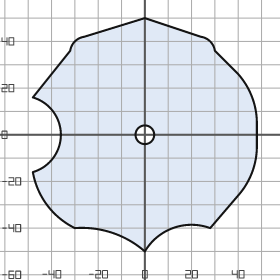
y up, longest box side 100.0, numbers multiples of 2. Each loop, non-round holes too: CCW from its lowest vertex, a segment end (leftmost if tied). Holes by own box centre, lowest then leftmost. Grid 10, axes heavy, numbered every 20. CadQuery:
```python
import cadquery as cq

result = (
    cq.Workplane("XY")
    .moveTo(0.0, -50.0)
    .threePointArc((12.0, -40.0), (28.0, -40.0))
    .lineTo(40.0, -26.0)
    .threePointArc((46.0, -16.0), (48.0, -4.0))
    .lineTo(48.0, 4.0)
    .threePointArc((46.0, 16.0), (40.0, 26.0))
    .lineTo(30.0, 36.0)
    .threePointArc((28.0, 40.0), (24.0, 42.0))
    .lineTo(0.0, 50.0)
    .lineTo(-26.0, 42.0)
    .threePointArc((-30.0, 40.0), (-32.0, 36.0))
    .lineTo(-48.0, 16.0)
    .threePointArc((-36.0, 0.0), (-48.0, -16.0))
    .threePointArc((-42.0, -30.0), (-30.0, -40.0))
    .threePointArc((-14.0, -42.0), (0.0, -50.0))
    .close()
    .moveTo(0.0, 0.0)
    .circle(4.0)
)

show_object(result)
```